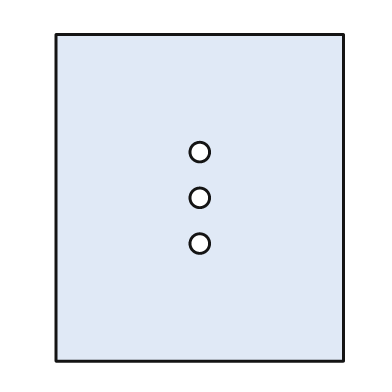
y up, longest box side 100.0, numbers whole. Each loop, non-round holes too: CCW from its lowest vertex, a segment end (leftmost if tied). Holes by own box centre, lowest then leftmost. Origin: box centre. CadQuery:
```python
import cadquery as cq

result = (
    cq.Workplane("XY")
    .moveTo(-44.0, -50.0)
    .lineTo(44.0, -50.0)
    .lineTo(44.0, 50.0)
    .lineTo(-44.0, 50.0)
    .close()
    .moveTo(0.0, -14.0)
    .circle(3.0)
    .moveTo(0.0, 0.0)
    .circle(3.0)
    .moveTo(0.0, 14.0)
    .circle(3.0)
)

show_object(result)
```